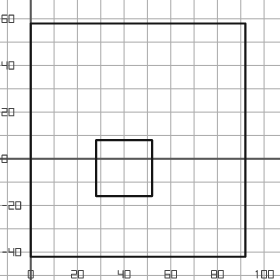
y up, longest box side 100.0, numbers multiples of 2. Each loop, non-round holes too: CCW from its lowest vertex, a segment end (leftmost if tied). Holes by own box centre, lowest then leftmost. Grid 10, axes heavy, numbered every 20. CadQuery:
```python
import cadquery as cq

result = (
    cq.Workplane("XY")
    .moveTo(0.0, -42.0)
    .lineTo(92.0, -42.0)
    .lineTo(92.0, 58.0)
    .lineTo(0.0, 58.0)
    .close()
    .moveTo(28.0, -16.0)
    .lineTo(52.0, -16.0)
    .lineTo(52.0, 8.0)
    .lineTo(28.0, 8.0)
    .close()
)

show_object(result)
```